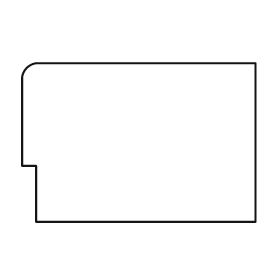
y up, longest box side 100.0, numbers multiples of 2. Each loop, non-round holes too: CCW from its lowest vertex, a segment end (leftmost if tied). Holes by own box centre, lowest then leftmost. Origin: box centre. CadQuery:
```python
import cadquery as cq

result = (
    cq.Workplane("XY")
    .moveTo(-44.0, -34.0)
    .lineTo(50.0, -34.0)
    .lineTo(50.0, 34.0)
    .lineTo(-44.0, 34.0)
    .threePointArc((-48.0, 32.0), (-50.0, 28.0))
    .lineTo(-50.0, -10.0)
    .lineTo(-44.0, -10.0)
    .close()
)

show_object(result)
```